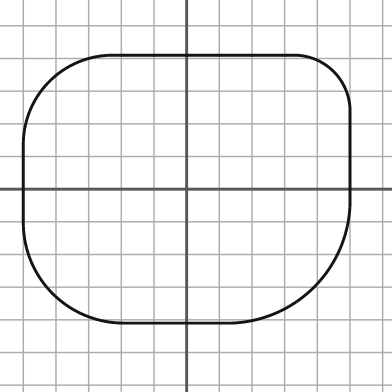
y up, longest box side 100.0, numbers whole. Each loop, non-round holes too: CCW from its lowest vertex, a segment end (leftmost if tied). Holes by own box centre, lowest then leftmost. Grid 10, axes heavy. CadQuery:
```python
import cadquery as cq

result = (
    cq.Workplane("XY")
    .moveTo(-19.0, -41.0)
    .lineTo(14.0, -41.0)
    .threePointArc((39.0, -30.0), (50.0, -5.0))
    .lineTo(50.0, 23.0)
    .threePointArc((45.0, 36.0), (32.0, 41.0))
    .lineTo(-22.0, 41.0)
    .threePointArc((-42.0, 33.0), (-50.0, 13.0))
    .lineTo(-50.0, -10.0)
    .threePointArc((-41.0, -32.0), (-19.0, -41.0))
    .close()
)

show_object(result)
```